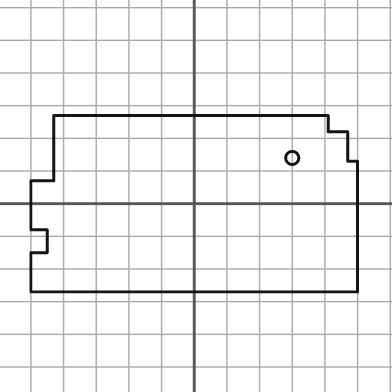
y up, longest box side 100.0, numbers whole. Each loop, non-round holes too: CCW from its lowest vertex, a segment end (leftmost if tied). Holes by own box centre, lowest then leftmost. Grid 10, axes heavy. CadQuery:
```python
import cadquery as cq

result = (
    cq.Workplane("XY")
    .moveTo(-50.0, -27.0)
    .lineTo(50.0, -27.0)
    .lineTo(50.0, 13.0)
    .lineTo(47.0, 13.0)
    .lineTo(47.0, 22.0)
    .lineTo(41.0, 22.0)
    .lineTo(41.0, 27.0)
    .lineTo(-43.0, 27.0)
    .lineTo(-43.0, 7.0)
    .lineTo(-50.0, 7.0)
    .lineTo(-50.0, -8.0)
    .lineTo(-45.0, -8.0)
    .lineTo(-45.0, -15.0)
    .lineTo(-50.0, -15.0)
    .close()
    .moveTo(30.0, 14.0)
    .circle(2.0)
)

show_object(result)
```